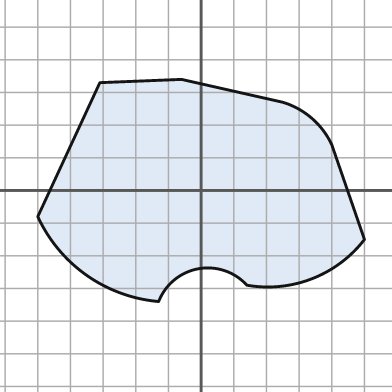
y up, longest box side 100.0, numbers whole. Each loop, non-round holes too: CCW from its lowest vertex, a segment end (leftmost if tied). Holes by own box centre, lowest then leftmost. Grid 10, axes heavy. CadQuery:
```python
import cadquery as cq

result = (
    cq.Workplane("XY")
    .moveTo(-13.0, -34.0)
    .threePointArc((-1.0, -24.0), (14.0, -29.0))
    .threePointArc((34.0, -27.0), (50.0, -15.0))
    .lineTo(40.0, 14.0)
    .threePointArc((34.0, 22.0), (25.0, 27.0))
    .lineTo(-6.0, 34.0)
    .lineTo(-31.0, 33.0)
    .lineTo(-50.0, -8.0)
    .threePointArc((-35.0, -26.0), (-13.0, -34.0))
    .close()
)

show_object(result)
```